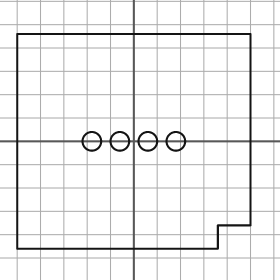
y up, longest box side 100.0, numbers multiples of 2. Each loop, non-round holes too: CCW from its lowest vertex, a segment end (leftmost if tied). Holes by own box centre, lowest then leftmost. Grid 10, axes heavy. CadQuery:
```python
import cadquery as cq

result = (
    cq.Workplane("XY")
    .moveTo(-50.0, -46.0)
    .lineTo(36.0, -46.0)
    .lineTo(36.0, -36.0)
    .lineTo(50.0, -36.0)
    .lineTo(50.0, 46.0)
    .lineTo(-50.0, 46.0)
    .close()
    .moveTo(-18.0, 0.0)
    .circle(4.0)
    .moveTo(-6.0, 0.0)
    .circle(4.0)
    .moveTo(6.0, 0.0)
    .circle(4.0)
    .moveTo(18.0, 0.0)
    .circle(4.0)
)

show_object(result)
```